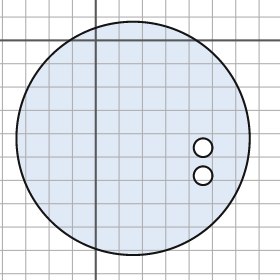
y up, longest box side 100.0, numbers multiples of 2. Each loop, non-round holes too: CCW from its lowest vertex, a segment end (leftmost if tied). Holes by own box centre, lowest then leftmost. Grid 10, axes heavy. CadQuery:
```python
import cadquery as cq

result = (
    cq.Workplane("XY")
    .moveTo(16.0, -42.0)
    .circle(50.0)
    .moveTo(46.0, -58.0)
    .circle(4.0)
    .moveTo(46.0, -46.0)
    .circle(4.0)
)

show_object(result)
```